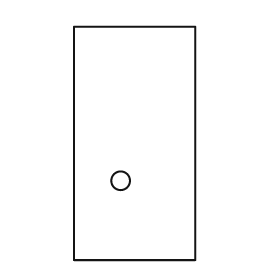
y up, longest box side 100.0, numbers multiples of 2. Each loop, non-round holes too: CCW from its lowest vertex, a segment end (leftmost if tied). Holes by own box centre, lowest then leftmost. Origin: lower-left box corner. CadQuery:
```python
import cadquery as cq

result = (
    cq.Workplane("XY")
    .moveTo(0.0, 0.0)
    .lineTo(52.0, 0.0)
    .lineTo(52.0, 100.0)
    .lineTo(0.0, 100.0)
    .close()
    .moveTo(20.0, 34.0)
    .circle(4.0)
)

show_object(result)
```